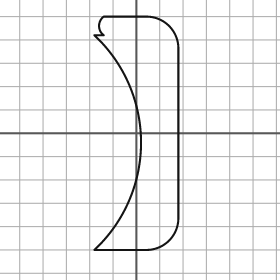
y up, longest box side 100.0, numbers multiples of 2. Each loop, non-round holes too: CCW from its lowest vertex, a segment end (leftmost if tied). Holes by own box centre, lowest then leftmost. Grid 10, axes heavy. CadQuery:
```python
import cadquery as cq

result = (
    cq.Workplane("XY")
    .moveTo(-18.0, -50.0)
    .lineTo(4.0, -50.0)
    .threePointArc((14.0, -46.0), (18.0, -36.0))
    .lineTo(18.0, 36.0)
    .threePointArc((14.0, 46.0), (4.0, 50.0))
    .lineTo(-14.0, 50.0)
    .threePointArc((-16.0, 46.0), (-14.0, 42.0))
    .lineTo(-18.0, 42.0)
    .threePointArc((2.0, -4.0), (-18.0, -50.0))
    .close()
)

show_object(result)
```